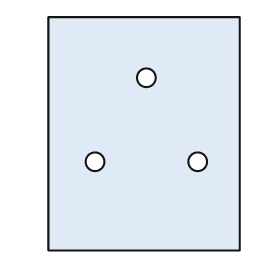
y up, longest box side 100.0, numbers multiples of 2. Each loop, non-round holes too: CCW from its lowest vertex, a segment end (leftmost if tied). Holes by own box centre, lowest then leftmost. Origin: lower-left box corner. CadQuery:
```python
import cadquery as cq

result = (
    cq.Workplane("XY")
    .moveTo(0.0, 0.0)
    .lineTo(82.0, 0.0)
    .lineTo(82.0, 100.0)
    .lineTo(0.0, 100.0)
    .close()
    .moveTo(20.0, 38.0)
    .circle(4.0)
    .moveTo(64.0, 38.0)
    .circle(4.0)
    .moveTo(42.0, 74.0)
    .circle(4.0)
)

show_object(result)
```